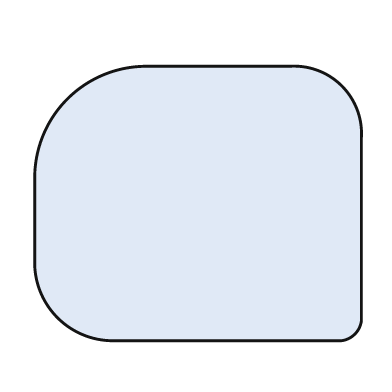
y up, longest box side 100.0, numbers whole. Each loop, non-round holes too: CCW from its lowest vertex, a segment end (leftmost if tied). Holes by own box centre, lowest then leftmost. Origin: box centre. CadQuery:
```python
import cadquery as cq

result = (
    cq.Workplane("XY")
    .moveTo(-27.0, -42.0)
    .lineTo(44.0, -42.0)
    .threePointArc((48.0, -40.0), (50.0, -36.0))
    .lineTo(50.0, 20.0)
    .threePointArc((44.0, 36.0), (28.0, 42.0))
    .lineTo(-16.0, 42.0)
    .threePointArc((-40.0, 32.0), (-50.0, 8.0))
    .lineTo(-50.0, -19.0)
    .threePointArc((-43.0, -35.0), (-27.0, -42.0))
    .close()
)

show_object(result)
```